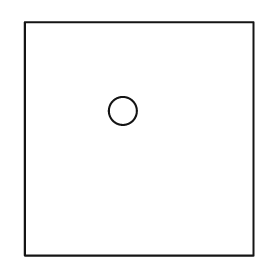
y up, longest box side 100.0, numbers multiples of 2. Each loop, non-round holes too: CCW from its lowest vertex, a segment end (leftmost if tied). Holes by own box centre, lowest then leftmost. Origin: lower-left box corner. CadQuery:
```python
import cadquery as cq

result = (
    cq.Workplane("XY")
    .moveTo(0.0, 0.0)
    .lineTo(98.0, 0.0)
    .lineTo(98.0, 100.0)
    .lineTo(0.0, 100.0)
    .close()
    .moveTo(42.0, 62.0)
    .circle(6.0)
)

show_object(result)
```